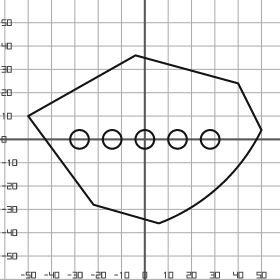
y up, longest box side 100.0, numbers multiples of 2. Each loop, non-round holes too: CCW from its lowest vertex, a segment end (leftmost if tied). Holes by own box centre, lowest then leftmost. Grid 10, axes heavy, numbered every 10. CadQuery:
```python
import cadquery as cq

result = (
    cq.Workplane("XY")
    .moveTo(6.0, -36.0)
    .threePointArc((32.0, -20.0), (50.0, 4.0))
    .lineTo(40.0, 24.0)
    .lineTo(-4.0, 36.0)
    .lineTo(-50.0, 10.0)
    .lineTo(-22.0, -28.0)
    .close()
    .moveTo(-28.0, 0.0)
    .circle(4.0)
    .moveTo(-14.0, 0.0)
    .circle(4.0)
    .moveTo(0.0, 0.0)
    .circle(4.0)
    .moveTo(14.0, 0.0)
    .circle(4.0)
    .moveTo(28.0, 0.0)
    .circle(4.0)
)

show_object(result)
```